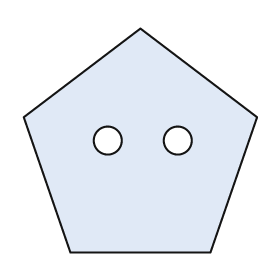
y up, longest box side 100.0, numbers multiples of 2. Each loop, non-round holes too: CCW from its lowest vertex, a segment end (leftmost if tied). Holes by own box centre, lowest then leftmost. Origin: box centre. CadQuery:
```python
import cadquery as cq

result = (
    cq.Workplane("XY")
    .moveTo(-30.0, -48.0)
    .lineTo(30.0, -48.0)
    .lineTo(50.0, 10.0)
    .lineTo(0.0, 48.0)
    .lineTo(-50.0, 10.0)
    .close()
    .moveTo(-14.0, 0.0)
    .circle(6.0)
    .moveTo(16.0, 0.0)
    .circle(6.0)
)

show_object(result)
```